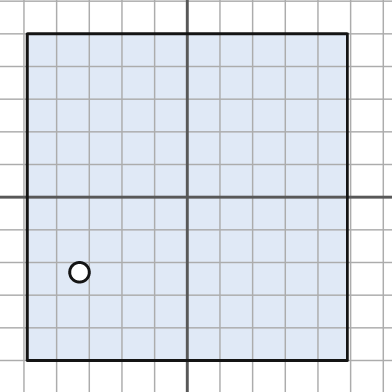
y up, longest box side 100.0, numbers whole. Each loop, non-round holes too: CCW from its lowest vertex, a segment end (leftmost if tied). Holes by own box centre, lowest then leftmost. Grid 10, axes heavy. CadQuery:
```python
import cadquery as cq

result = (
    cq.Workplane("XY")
    .moveTo(-49.0, -50.0)
    .lineTo(49.0, -50.0)
    .lineTo(49.0, 50.0)
    .lineTo(-49.0, 50.0)
    .close()
    .moveTo(-33.0, -23.0)
    .circle(3.0)
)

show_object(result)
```